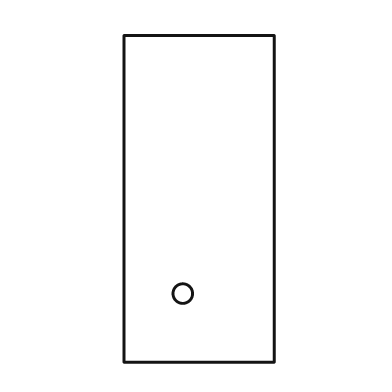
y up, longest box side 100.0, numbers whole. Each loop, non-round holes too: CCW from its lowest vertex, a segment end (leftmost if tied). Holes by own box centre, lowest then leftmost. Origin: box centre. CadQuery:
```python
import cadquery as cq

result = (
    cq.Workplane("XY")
    .moveTo(-23.0, -50.0)
    .lineTo(23.0, -50.0)
    .lineTo(23.0, 50.0)
    .lineTo(-23.0, 50.0)
    .close()
    .moveTo(-5.0, -29.0)
    .circle(3.0)
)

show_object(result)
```